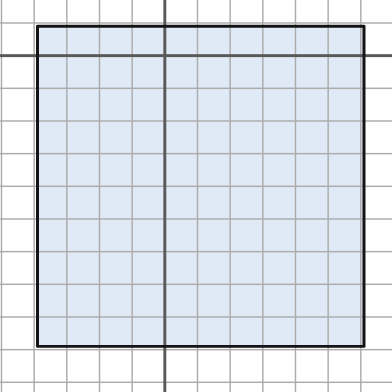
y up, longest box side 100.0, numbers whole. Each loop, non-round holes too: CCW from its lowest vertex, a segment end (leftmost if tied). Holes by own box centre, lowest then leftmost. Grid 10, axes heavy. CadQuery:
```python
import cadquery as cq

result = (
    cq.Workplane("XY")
    .moveTo(-39.0, -89.0)
    .lineTo(61.0, -89.0)
    .lineTo(61.0, 9.0)
    .lineTo(-39.0, 9.0)
    .close()
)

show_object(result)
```